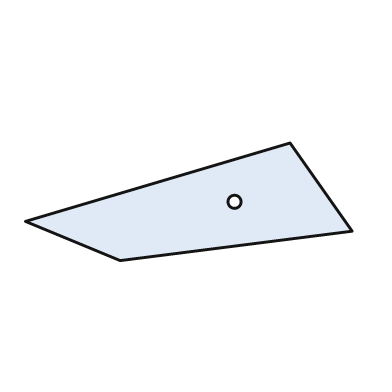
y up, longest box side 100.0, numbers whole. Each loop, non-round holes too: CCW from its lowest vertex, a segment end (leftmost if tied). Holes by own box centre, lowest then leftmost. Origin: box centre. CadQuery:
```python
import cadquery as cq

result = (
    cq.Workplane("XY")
    .moveTo(-21.0, -18.0)
    .lineTo(50.0, -9.0)
    .lineTo(31.0, 18.0)
    .lineTo(-50.0, -6.0)
    .close()
    .moveTo(14.0, 0.0)
    .circle(2.0)
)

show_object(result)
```